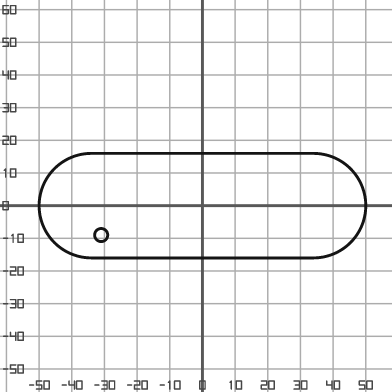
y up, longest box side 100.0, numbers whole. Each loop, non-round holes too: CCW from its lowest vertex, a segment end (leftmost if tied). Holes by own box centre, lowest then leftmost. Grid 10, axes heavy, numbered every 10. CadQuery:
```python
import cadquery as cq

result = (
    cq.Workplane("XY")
    .moveTo(-34.0, -16.0)
    .lineTo(34.0, -16.0)
    .threePointArc((50.0, 0.0), (34.0, 16.0))
    .lineTo(-34.0, 16.0)
    .threePointArc((-50.0, 0.0), (-34.0, -16.0))
    .close()
    .moveTo(-31.0, -9.0)
    .circle(2.0)
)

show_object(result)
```